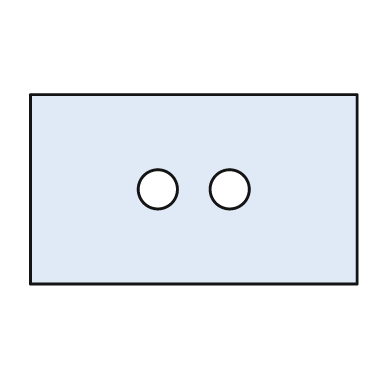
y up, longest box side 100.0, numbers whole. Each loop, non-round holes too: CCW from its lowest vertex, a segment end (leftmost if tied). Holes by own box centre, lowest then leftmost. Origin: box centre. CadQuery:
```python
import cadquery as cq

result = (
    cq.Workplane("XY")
    .moveTo(-50.0, -29.0)
    .lineTo(50.0, -29.0)
    .lineTo(50.0, 29.0)
    .lineTo(-50.0, 29.0)
    .close()
    .moveTo(-11.0, 0.0)
    .circle(6.0)
    .moveTo(11.0, 0.0)
    .circle(6.0)
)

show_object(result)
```